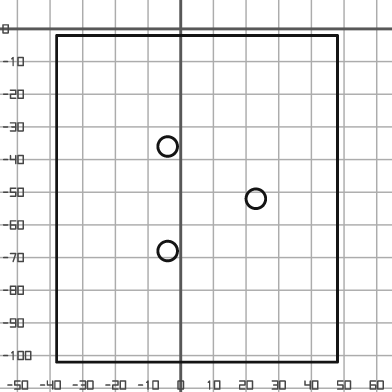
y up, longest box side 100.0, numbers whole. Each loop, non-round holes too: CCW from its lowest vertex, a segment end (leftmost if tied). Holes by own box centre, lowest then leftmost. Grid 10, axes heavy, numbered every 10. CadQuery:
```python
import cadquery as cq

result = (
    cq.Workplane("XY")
    .moveTo(-38.0, -102.0)
    .lineTo(48.0, -102.0)
    .lineTo(48.0, -2.0)
    .lineTo(-38.0, -2.0)
    .close()
    .moveTo(-4.0, -68.0)
    .circle(3.0)
    .moveTo(23.0, -52.0)
    .circle(3.0)
    .moveTo(-4.0, -36.0)
    .circle(3.0)
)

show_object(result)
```